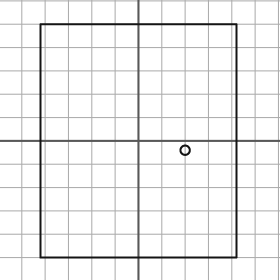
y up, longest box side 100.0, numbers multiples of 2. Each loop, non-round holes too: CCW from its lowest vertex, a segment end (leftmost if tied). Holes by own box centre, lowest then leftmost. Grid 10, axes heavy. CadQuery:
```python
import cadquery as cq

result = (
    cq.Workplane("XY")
    .moveTo(-42.0, -50.0)
    .lineTo(42.0, -50.0)
    .lineTo(42.0, 50.0)
    .lineTo(-42.0, 50.0)
    .close()
    .moveTo(20.0, -4.0)
    .circle(2.0)
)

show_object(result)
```